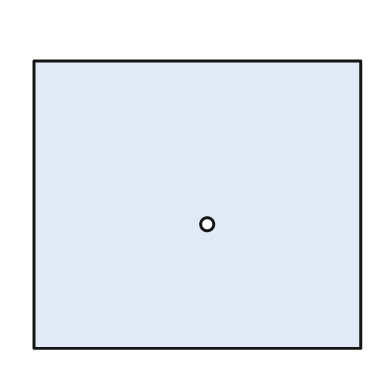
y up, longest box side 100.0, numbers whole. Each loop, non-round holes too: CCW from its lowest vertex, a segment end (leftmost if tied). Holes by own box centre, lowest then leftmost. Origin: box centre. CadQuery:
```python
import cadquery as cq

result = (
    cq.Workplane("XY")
    .moveTo(-50.0, -44.0)
    .lineTo(50.0, -44.0)
    .lineTo(50.0, 44.0)
    .lineTo(-50.0, 44.0)
    .close()
    .moveTo(3.0, -6.0)
    .circle(2.0)
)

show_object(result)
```